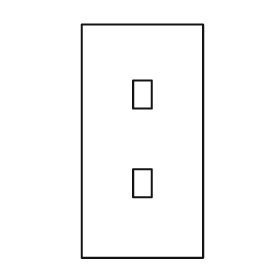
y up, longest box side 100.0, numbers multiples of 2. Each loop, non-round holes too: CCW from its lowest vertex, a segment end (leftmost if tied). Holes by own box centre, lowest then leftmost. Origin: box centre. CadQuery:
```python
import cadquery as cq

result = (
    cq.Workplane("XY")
    .moveTo(-26.0, -50.0)
    .lineTo(26.0, -50.0)
    .lineTo(26.0, 50.0)
    .lineTo(-26.0, 50.0)
    .close()
    .moveTo(-4.0, -24.0)
    .lineTo(4.0, -24.0)
    .lineTo(4.0, -12.0)
    .lineTo(-4.0, -12.0)
    .close()
    .moveTo(-4.0, 14.0)
    .lineTo(4.0, 14.0)
    .lineTo(4.0, 26.0)
    .lineTo(-4.0, 26.0)
    .close()
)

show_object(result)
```